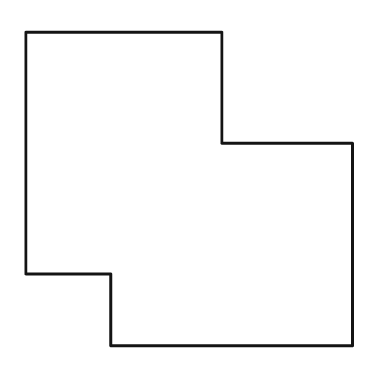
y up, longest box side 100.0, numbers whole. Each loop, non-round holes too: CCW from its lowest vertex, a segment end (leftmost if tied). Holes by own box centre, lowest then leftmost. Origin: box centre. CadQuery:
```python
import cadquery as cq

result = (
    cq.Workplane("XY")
    .moveTo(-24.0, -48.0)
    .lineTo(50.0, -48.0)
    .lineTo(50.0, 14.0)
    .lineTo(10.0, 14.0)
    .lineTo(10.0, 48.0)
    .lineTo(-50.0, 48.0)
    .lineTo(-50.0, -26.0)
    .lineTo(-24.0, -26.0)
    .close()
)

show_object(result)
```